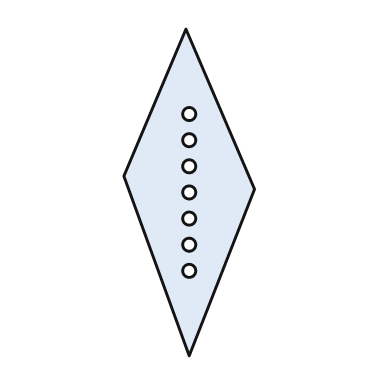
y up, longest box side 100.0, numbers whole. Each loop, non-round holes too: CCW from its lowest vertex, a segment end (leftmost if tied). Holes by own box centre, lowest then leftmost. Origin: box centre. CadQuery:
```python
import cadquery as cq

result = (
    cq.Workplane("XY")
    .moveTo(0.0, -50.0)
    .lineTo(20.0, 1.0)
    .lineTo(-1.0, 50.0)
    .lineTo(-20.0, 5.0)
    .close()
    .moveTo(0.0, -24.0)
    .circle(2.0)
    .moveTo(0.0, -16.0)
    .circle(2.0)
    .moveTo(0.0, -8.0)
    .circle(2.0)
    .moveTo(0.0, 0.0)
    .circle(2.0)
    .moveTo(0.0, 8.0)
    .circle(2.0)
    .moveTo(0.0, 16.0)
    .circle(2.0)
    .moveTo(0.0, 24.0)
    .circle(2.0)
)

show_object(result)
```